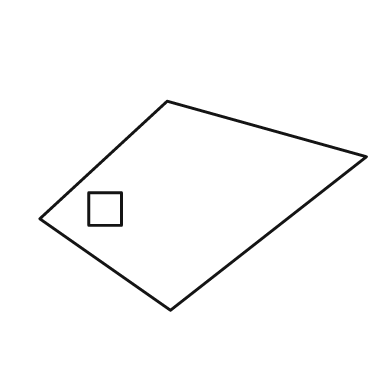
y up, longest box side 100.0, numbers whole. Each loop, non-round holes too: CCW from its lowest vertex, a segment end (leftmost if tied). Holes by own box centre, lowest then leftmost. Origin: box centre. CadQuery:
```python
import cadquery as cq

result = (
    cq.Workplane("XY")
    .moveTo(-10.0, -32.0)
    .lineTo(50.0, 15.0)
    .lineTo(-11.0, 32.0)
    .lineTo(-50.0, -4.0)
    .close()
    .moveTo(-35.0, -6.0)
    .lineTo(-25.0, -6.0)
    .lineTo(-25.0, 4.0)
    .lineTo(-35.0, 4.0)
    .close()
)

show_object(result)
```